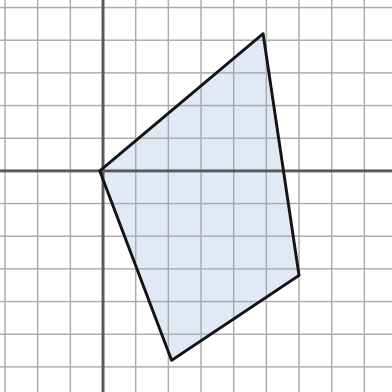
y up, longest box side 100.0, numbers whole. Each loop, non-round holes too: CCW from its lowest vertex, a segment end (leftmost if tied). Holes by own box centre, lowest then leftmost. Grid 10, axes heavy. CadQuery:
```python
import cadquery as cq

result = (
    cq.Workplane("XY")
    .moveTo(21.0, -58.0)
    .lineTo(60.0, -32.0)
    .lineTo(49.0, 42.0)
    .lineTo(-1.0, 0.0)
    .close()
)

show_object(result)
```